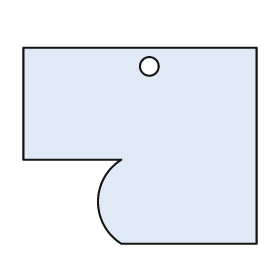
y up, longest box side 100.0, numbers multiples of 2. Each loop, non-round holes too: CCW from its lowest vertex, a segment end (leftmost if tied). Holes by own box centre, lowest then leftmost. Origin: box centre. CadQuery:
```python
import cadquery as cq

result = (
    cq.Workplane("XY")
    .moveTo(-8.0, -42.0)
    .lineTo(50.0, -42.0)
    .lineTo(50.0, 42.0)
    .lineTo(-50.0, 42.0)
    .lineTo(-50.0, -6.0)
    .lineTo(-8.0, -6.0)
    .threePointArc((-18.0, -24.0), (-8.0, -42.0))
    .close()
    .moveTo(4.0, 34.0)
    .circle(4.0)
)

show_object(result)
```